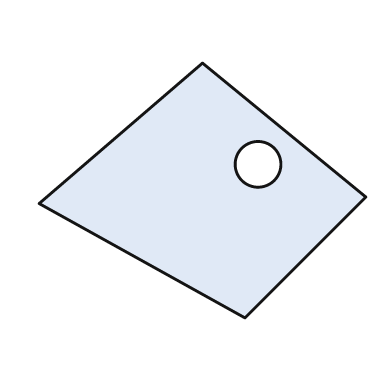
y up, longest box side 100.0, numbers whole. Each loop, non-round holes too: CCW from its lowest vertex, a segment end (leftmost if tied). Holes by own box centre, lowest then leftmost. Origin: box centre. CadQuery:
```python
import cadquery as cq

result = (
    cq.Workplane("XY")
    .moveTo(13.0, -39.0)
    .lineTo(50.0, -2.0)
    .lineTo(0.0, 39.0)
    .lineTo(-50.0, -4.0)
    .close()
    .moveTo(17.0, 8.0)
    .circle(7.0)
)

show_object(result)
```